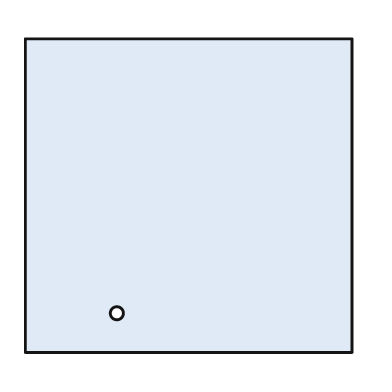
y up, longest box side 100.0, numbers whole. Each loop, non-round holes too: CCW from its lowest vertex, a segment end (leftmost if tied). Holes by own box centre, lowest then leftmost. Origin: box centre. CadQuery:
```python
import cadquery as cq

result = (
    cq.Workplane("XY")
    .moveTo(-50.0, -48.0)
    .lineTo(50.0, -48.0)
    .lineTo(50.0, 48.0)
    .lineTo(-50.0, 48.0)
    .close()
    .moveTo(-22.0, -36.0)
    .circle(2.0)
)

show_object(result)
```